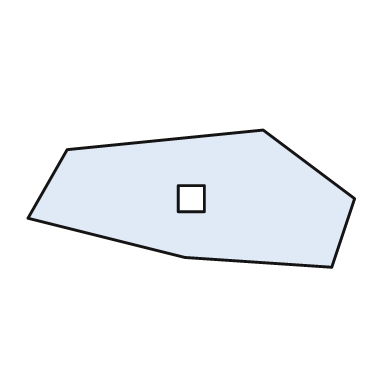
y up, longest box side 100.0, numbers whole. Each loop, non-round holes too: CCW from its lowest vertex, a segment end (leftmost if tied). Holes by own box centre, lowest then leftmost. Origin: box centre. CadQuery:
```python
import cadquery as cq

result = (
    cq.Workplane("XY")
    .moveTo(43.0, -21.0)
    .lineTo(50.0, 0.0)
    .lineTo(22.0, 21.0)
    .lineTo(-38.0, 15.0)
    .lineTo(-50.0, -6.0)
    .lineTo(-2.0, -18.0)
    .close()
    .moveTo(-4.0, -4.0)
    .lineTo(4.0, -4.0)
    .lineTo(4.0, 4.0)
    .lineTo(-4.0, 4.0)
    .close()
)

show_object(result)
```